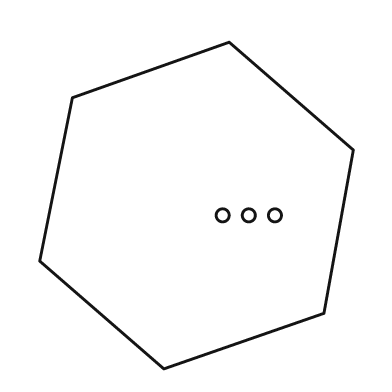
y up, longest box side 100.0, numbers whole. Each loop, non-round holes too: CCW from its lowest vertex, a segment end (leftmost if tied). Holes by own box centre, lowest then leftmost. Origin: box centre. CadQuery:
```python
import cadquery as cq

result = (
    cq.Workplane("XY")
    .moveTo(-10.0, -50.0)
    .lineTo(39.0, -33.0)
    .lineTo(48.0, 17.0)
    .lineTo(10.0, 50.0)
    .lineTo(-38.0, 33.0)
    .lineTo(-48.0, -17.0)
    .close()
    .moveTo(8.0, -3.0)
    .circle(2.0)
    .moveTo(16.0, -3.0)
    .circle(2.0)
    .moveTo(24.0, -3.0)
    .circle(2.0)
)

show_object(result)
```